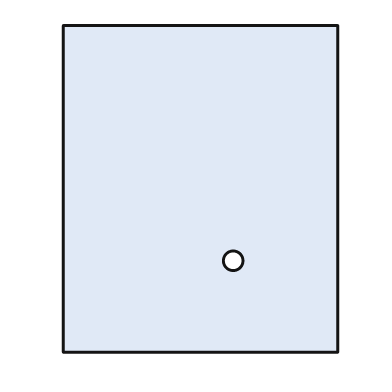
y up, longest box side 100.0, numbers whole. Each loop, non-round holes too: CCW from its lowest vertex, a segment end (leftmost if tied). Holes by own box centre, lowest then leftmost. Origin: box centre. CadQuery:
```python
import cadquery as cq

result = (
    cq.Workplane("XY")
    .moveTo(-42.0, -50.0)
    .lineTo(42.0, -50.0)
    .lineTo(42.0, 50.0)
    .lineTo(-42.0, 50.0)
    .close()
    .moveTo(10.0, -22.0)
    .circle(3.0)
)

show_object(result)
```